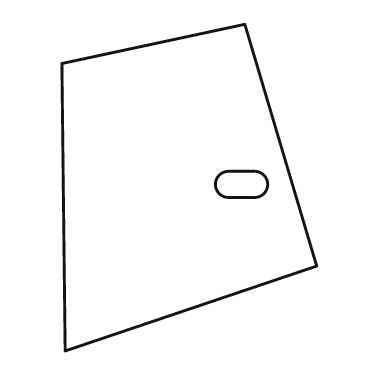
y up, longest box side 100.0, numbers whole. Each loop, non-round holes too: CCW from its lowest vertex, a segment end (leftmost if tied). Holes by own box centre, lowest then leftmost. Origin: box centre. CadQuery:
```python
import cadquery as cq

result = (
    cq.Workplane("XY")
    .moveTo(-38.0, -50.0)
    .lineTo(39.0, -24.0)
    .lineTo(17.0, 50.0)
    .lineTo(-39.0, 38.0)
    .close()
    .moveTo(12.0, -3.0)
    .lineTo(20.0, -3.0)
    .threePointArc((24.0, 1.0), (20.0, 5.0))
    .lineTo(12.0, 5.0)
    .threePointArc((8.0, 1.0), (12.0, -3.0))
    .close()
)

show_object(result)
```